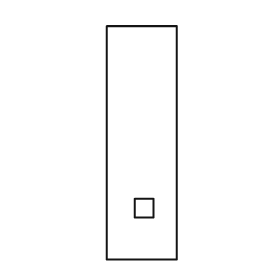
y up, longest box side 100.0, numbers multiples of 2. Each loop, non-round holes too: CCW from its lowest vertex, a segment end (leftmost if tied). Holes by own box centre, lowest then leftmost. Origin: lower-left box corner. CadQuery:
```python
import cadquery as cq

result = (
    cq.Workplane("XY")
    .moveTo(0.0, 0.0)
    .lineTo(30.0, 0.0)
    .lineTo(30.0, 100.0)
    .lineTo(0.0, 100.0)
    .close()
    .moveTo(12.0, 18.0)
    .lineTo(20.0, 18.0)
    .lineTo(20.0, 26.0)
    .lineTo(12.0, 26.0)
    .close()
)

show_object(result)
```